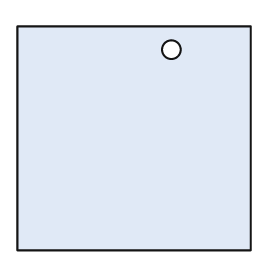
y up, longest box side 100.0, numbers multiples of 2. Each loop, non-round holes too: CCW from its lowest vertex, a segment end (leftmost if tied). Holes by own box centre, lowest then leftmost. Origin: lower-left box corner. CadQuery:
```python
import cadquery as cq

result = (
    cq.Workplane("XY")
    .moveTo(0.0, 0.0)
    .lineTo(100.0, 0.0)
    .lineTo(100.0, 96.0)
    .lineTo(0.0, 96.0)
    .close()
    .moveTo(66.0, 86.0)
    .circle(4.0)
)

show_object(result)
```